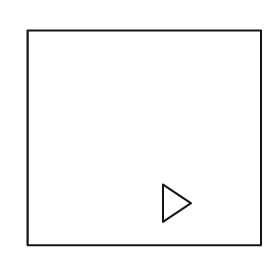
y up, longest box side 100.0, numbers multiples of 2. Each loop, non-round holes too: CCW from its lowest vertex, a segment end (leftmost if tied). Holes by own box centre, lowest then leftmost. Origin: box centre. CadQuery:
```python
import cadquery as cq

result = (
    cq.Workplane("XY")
    .moveTo(-50.0, -46.0)
    .lineTo(50.0, -46.0)
    .lineTo(50.0, 46.0)
    .lineTo(-50.0, 46.0)
    .close()
    .moveTo(8.0, -36.0)
    .lineTo(20.0, -28.0)
    .lineTo(8.0, -20.0)
    .close()
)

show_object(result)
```